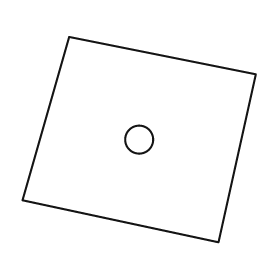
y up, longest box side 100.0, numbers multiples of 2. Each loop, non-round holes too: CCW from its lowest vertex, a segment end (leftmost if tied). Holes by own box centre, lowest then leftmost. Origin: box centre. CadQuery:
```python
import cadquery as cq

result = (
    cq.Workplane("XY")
    .moveTo(34.0, -44.0)
    .lineTo(50.0, 28.0)
    .lineTo(-30.0, 44.0)
    .lineTo(-50.0, -26.0)
    .close()
    .moveTo(0.0, 0.0)
    .circle(6.0)
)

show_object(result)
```